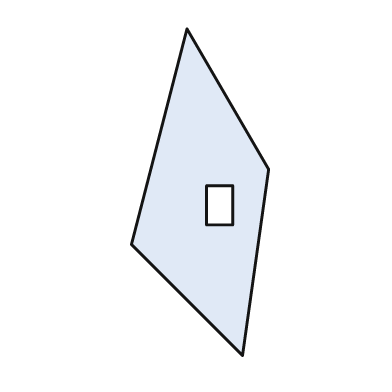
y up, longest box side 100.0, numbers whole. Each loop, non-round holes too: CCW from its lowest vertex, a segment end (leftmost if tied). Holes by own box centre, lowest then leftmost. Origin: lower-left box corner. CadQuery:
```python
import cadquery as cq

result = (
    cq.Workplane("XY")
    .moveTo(34.0, 0.0)
    .lineTo(42.0, 57.0)
    .lineTo(17.0, 100.0)
    .lineTo(0.0, 34.0)
    .close()
    .moveTo(23.0, 40.0)
    .lineTo(31.0, 40.0)
    .lineTo(31.0, 52.0)
    .lineTo(23.0, 52.0)
    .close()
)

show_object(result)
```